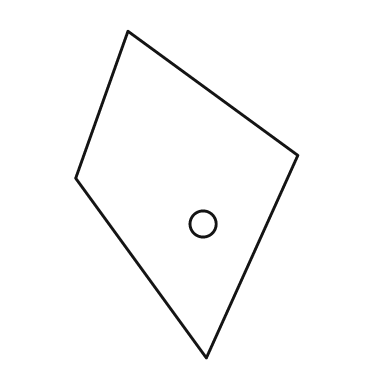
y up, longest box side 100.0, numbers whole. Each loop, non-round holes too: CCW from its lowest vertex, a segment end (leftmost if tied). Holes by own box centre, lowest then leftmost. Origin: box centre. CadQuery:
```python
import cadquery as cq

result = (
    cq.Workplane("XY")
    .moveTo(6.0, -50.0)
    .lineTo(34.0, 12.0)
    .lineTo(-18.0, 50.0)
    .lineTo(-34.0, 5.0)
    .close()
    .moveTo(5.0, -9.0)
    .circle(4.0)
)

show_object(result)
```